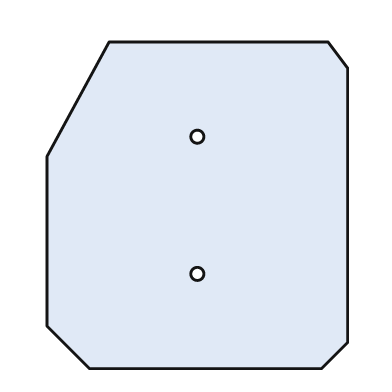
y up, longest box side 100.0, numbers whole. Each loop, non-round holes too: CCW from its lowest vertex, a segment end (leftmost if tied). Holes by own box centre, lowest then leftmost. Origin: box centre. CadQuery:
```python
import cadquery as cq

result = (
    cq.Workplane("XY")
    .moveTo(-33.0, -50.0)
    .lineTo(38.0, -50.0)
    .lineTo(46.0, -42.0)
    .lineTo(46.0, 42.0)
    .lineTo(40.0, 50.0)
    .lineTo(-27.0, 50.0)
    .lineTo(-46.0, 15.0)
    .lineTo(-46.0, -37.0)
    .close()
    .moveTo(0.0, -21.0)
    .circle(2.0)
    .moveTo(0.0, 21.0)
    .circle(2.0)
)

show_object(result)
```